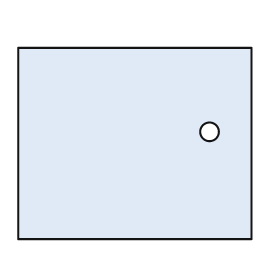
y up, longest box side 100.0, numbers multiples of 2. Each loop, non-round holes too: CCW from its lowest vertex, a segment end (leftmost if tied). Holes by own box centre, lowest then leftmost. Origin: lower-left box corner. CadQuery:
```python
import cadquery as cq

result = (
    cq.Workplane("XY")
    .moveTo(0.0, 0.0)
    .lineTo(100.0, 0.0)
    .lineTo(100.0, 82.0)
    .lineTo(0.0, 82.0)
    .close()
    .moveTo(82.0, 46.0)
    .circle(4.0)
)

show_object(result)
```